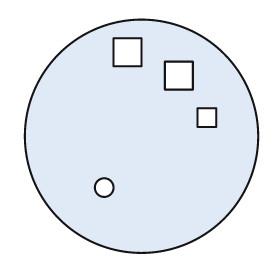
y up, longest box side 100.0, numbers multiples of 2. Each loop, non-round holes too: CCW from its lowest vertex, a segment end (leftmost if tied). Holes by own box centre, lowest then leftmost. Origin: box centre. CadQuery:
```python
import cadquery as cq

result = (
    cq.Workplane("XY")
    .moveTo(0.0, 0.0)
    .circle(50.0)
    .moveTo(-16.0, -22.0)
    .circle(4.0)
    .moveTo(24.0, 4.0)
    .lineTo(32.0, 4.0)
    .lineTo(32.0, 12.0)
    .lineTo(24.0, 12.0)
    .close()
    .moveTo(10.0, 20.0)
    .lineTo(22.0, 20.0)
    .lineTo(22.0, 32.0)
    .lineTo(10.0, 32.0)
    .close()
    .moveTo(-12.0, 30.0)
    .lineTo(0.0, 30.0)
    .lineTo(0.0, 42.0)
    .lineTo(-12.0, 42.0)
    .close()
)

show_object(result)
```